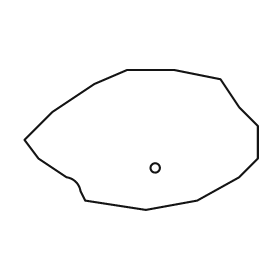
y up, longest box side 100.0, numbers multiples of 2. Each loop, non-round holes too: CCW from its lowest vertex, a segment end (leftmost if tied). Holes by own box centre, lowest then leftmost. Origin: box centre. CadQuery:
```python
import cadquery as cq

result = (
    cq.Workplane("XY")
    .moveTo(2.0, -30.0)
    .lineTo(24.0, -26.0)
    .lineTo(42.0, -16.0)
    .lineTo(50.0, -8.0)
    .lineTo(50.0, 6.0)
    .lineTo(42.0, 14.0)
    .lineTo(34.0, 26.0)
    .lineTo(14.0, 30.0)
    .lineTo(-6.0, 30.0)
    .lineTo(-20.0, 24.0)
    .lineTo(-38.0, 12.0)
    .lineTo(-50.0, 0.0)
    .lineTo(-44.0, -8.0)
    .lineTo(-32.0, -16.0)
    .threePointArc((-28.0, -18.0), (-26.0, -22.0))
    .lineTo(-24.0, -26.0)
    .close()
    .moveTo(6.0, -12.0)
    .circle(2.0)
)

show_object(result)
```